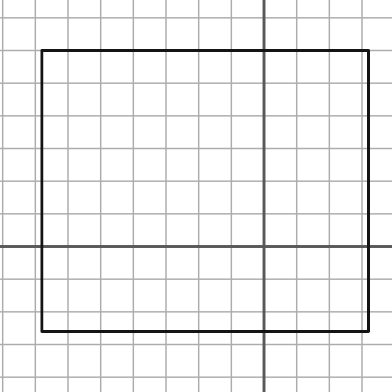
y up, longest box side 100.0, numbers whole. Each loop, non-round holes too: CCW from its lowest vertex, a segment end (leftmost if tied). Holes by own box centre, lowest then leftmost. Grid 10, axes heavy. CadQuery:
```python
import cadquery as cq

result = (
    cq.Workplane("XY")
    .moveTo(-68.0, -26.0)
    .lineTo(32.0, -26.0)
    .lineTo(32.0, 60.0)
    .lineTo(-68.0, 60.0)
    .close()
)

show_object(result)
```